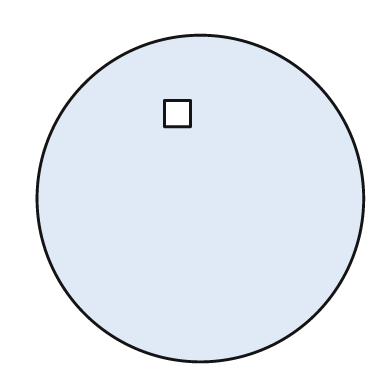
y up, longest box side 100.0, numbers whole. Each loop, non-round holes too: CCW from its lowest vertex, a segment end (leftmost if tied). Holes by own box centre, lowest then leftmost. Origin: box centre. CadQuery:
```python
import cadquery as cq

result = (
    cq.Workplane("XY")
    .moveTo(0.0, 0.0)
    .circle(50.0)
    .moveTo(-11.0, 22.0)
    .lineTo(-3.0, 22.0)
    .lineTo(-3.0, 30.0)
    .lineTo(-11.0, 30.0)
    .close()
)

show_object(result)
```